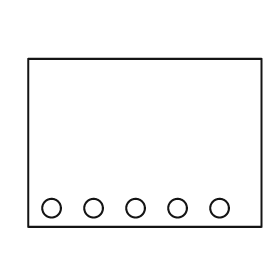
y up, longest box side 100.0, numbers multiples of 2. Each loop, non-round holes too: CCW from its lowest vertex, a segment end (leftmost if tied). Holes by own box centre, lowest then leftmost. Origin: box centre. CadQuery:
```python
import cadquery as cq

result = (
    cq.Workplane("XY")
    .moveTo(-50.0, -36.0)
    .lineTo(50.0, -36.0)
    .lineTo(50.0, 36.0)
    .lineTo(-50.0, 36.0)
    .close()
    .moveTo(-40.0, -28.0)
    .circle(4.0)
    .moveTo(-22.0, -28.0)
    .circle(4.0)
    .moveTo(-4.0, -28.0)
    .circle(4.0)
    .moveTo(14.0, -28.0)
    .circle(4.0)
    .moveTo(32.0, -28.0)
    .circle(4.0)
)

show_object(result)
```